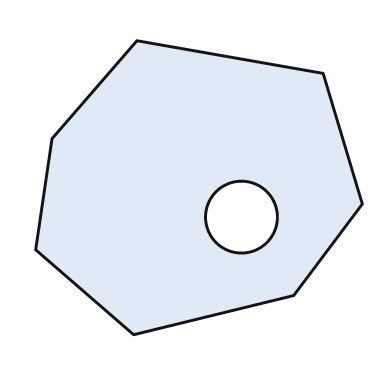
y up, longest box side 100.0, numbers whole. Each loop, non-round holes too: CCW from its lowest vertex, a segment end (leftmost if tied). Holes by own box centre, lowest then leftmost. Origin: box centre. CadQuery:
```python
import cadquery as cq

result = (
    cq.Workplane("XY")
    .moveTo(-20.0, -45.0)
    .lineTo(29.0, -33.0)
    .lineTo(50.0, -5.0)
    .lineTo(38.0, 35.0)
    .lineTo(-19.0, 45.0)
    .lineTo(-45.0, 15.0)
    .lineTo(-50.0, -19.0)
    .close()
    .moveTo(13.0, -9.0)
    .circle(11.0)
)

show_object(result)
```